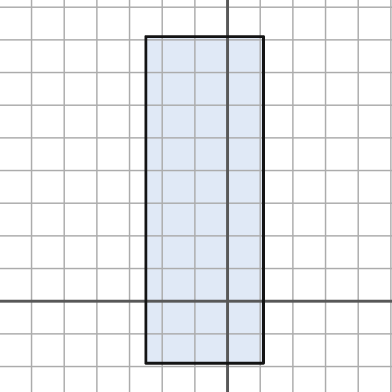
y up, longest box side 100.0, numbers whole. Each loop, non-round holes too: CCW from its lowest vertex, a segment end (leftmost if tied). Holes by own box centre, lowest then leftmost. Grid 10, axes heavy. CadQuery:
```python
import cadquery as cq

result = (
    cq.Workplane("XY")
    .moveTo(-25.0, -19.0)
    .lineTo(11.0, -19.0)
    .lineTo(11.0, 81.0)
    .lineTo(-25.0, 81.0)
    .close()
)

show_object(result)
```